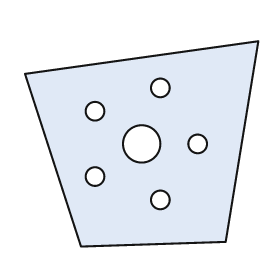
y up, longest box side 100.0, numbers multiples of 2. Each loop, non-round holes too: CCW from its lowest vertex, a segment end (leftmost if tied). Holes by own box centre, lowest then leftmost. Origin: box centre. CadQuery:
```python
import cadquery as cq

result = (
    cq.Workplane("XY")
    .moveTo(-26.0, -44.0)
    .lineTo(36.0, -42.0)
    .lineTo(50.0, 44.0)
    .lineTo(-50.0, 30.0)
    .close()
    .moveTo(8.0, -24.0)
    .circle(4.0)
    .moveTo(-20.0, -14.0)
    .circle(4.0)
    .moveTo(0.0, 0.0)
    .circle(8.0)
    .moveTo(24.0, 0.0)
    .circle(4.0)
    .moveTo(-20.0, 14.0)
    .circle(4.0)
    .moveTo(8.0, 24.0)
    .circle(4.0)
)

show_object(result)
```